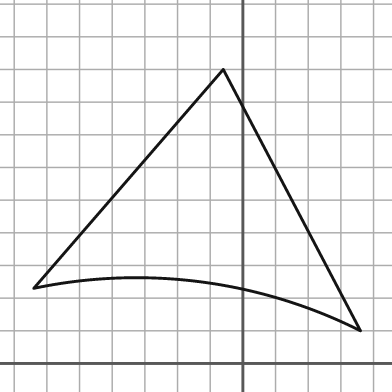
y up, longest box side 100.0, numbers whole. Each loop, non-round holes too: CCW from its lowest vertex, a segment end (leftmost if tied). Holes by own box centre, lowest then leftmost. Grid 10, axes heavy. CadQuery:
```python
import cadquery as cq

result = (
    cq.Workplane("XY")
    .moveTo(36.0, 10.0)
    .lineTo(-6.0, 90.0)
    .lineTo(-64.0, 23.0)
    .threePointArc((-13.0, 25.0), (36.0, 10.0))
    .close()
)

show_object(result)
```